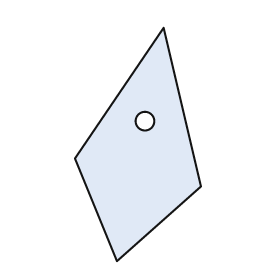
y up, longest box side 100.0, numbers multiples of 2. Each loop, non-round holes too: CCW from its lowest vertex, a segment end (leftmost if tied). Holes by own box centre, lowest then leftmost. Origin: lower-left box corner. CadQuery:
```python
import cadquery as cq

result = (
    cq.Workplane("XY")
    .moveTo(18.0, 0.0)
    .lineTo(54.0, 32.0)
    .lineTo(38.0, 100.0)
    .lineTo(0.0, 44.0)
    .close()
    .moveTo(30.0, 60.0)
    .circle(4.0)
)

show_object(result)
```